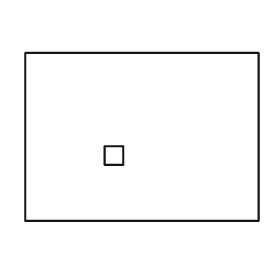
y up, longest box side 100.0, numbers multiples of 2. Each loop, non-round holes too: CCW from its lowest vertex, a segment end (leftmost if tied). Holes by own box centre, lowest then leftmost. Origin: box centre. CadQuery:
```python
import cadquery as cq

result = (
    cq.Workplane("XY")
    .moveTo(-50.0, -36.0)
    .lineTo(50.0, -36.0)
    .lineTo(50.0, 36.0)
    .lineTo(-50.0, 36.0)
    .close()
    .moveTo(-16.0, -12.0)
    .lineTo(-8.0, -12.0)
    .lineTo(-8.0, -4.0)
    .lineTo(-16.0, -4.0)
    .close()
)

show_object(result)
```